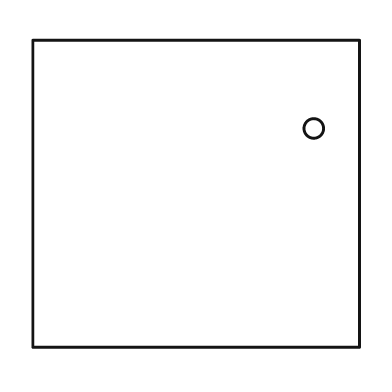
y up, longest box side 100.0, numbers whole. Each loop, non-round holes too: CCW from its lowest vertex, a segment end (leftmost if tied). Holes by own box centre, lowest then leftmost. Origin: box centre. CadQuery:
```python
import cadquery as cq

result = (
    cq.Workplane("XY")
    .moveTo(-50.0, -47.0)
    .lineTo(50.0, -47.0)
    .lineTo(50.0, 47.0)
    .lineTo(-50.0, 47.0)
    .close()
    .moveTo(36.0, 20.0)
    .circle(3.0)
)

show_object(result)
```